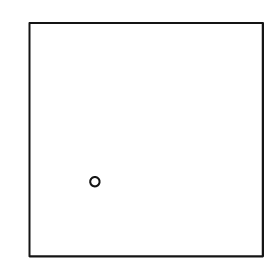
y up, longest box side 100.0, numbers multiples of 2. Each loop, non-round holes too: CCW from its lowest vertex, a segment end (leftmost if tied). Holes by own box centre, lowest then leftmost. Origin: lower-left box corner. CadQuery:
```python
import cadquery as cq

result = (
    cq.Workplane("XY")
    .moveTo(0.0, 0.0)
    .lineTo(100.0, 0.0)
    .lineTo(100.0, 100.0)
    .lineTo(0.0, 100.0)
    .close()
    .moveTo(28.0, 32.0)
    .circle(2.0)
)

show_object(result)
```